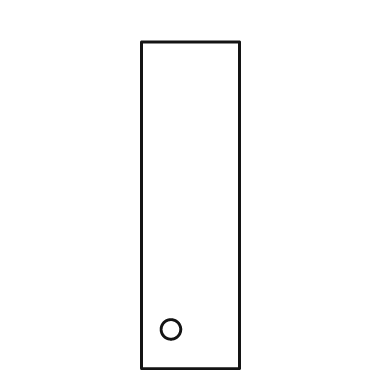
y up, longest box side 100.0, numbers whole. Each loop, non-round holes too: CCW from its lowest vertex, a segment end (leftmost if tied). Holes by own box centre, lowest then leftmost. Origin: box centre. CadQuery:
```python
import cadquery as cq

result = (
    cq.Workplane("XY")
    .moveTo(-15.0, -50.0)
    .lineTo(15.0, -50.0)
    .lineTo(15.0, 50.0)
    .lineTo(-15.0, 50.0)
    .close()
    .moveTo(-6.0, -38.0)
    .circle(3.0)
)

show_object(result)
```